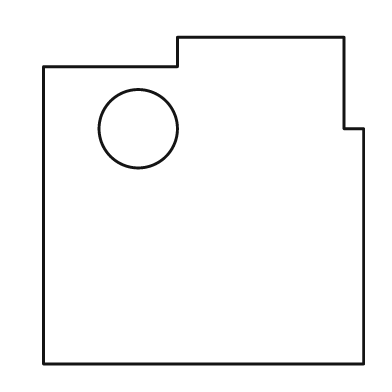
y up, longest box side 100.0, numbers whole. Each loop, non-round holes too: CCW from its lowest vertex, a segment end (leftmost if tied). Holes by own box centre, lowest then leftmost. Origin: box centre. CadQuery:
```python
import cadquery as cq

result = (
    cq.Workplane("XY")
    .moveTo(-49.0, -50.0)
    .lineTo(49.0, -50.0)
    .lineTo(49.0, 22.0)
    .lineTo(43.0, 22.0)
    .lineTo(43.0, 50.0)
    .lineTo(-8.0, 50.0)
    .lineTo(-8.0, 41.0)
    .lineTo(-49.0, 41.0)
    .close()
    .moveTo(-20.0, 22.0)
    .circle(12.0)
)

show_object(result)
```